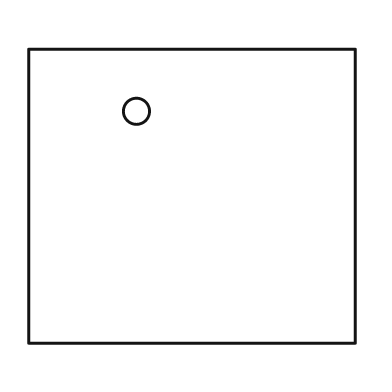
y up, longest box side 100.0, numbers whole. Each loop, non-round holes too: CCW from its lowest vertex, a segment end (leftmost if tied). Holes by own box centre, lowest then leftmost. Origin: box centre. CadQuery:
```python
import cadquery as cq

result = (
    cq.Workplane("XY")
    .moveTo(-50.0, -45.0)
    .lineTo(50.0, -45.0)
    .lineTo(50.0, 45.0)
    .lineTo(-50.0, 45.0)
    .close()
    .moveTo(-17.0, 26.0)
    .circle(4.0)
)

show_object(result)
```